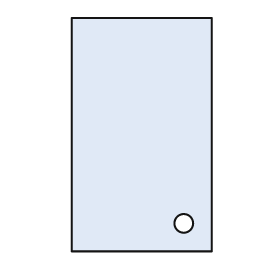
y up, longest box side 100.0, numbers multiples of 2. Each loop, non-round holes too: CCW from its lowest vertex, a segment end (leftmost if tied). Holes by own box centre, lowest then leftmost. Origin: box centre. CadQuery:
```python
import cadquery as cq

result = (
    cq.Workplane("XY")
    .moveTo(-30.0, -50.0)
    .lineTo(30.0, -50.0)
    .lineTo(30.0, 50.0)
    .lineTo(-30.0, 50.0)
    .close()
    .moveTo(18.0, -38.0)
    .circle(4.0)
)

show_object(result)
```